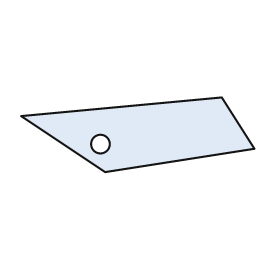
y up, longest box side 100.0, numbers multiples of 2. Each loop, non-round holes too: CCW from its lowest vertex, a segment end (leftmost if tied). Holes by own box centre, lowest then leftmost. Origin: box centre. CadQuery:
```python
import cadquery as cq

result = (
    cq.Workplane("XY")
    .moveTo(-14.0, -16.0)
    .lineTo(50.0, -6.0)
    .lineTo(36.0, 16.0)
    .lineTo(-50.0, 8.0)
    .close()
    .moveTo(-16.0, -4.0)
    .circle(4.0)
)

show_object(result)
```